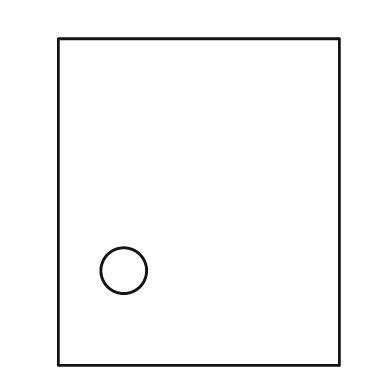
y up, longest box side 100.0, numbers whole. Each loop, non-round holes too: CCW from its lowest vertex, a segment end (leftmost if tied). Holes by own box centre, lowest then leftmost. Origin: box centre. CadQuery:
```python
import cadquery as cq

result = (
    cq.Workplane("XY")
    .moveTo(-43.0, -50.0)
    .lineTo(43.0, -50.0)
    .lineTo(43.0, 50.0)
    .lineTo(-43.0, 50.0)
    .close()
    .moveTo(-23.0, -21.0)
    .circle(7.0)
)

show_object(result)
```